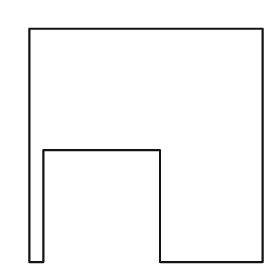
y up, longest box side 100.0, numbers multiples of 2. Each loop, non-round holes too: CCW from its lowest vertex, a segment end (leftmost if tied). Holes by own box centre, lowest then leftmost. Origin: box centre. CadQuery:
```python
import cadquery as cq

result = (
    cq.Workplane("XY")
    .moveTo(-50.0, -50.0)
    .lineTo(-44.0, -50.0)
    .lineTo(-44.0, -2.0)
    .lineTo(6.0, -2.0)
    .lineTo(6.0, -50.0)
    .lineTo(50.0, -50.0)
    .lineTo(50.0, 50.0)
    .lineTo(-50.0, 50.0)
    .close()
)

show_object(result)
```